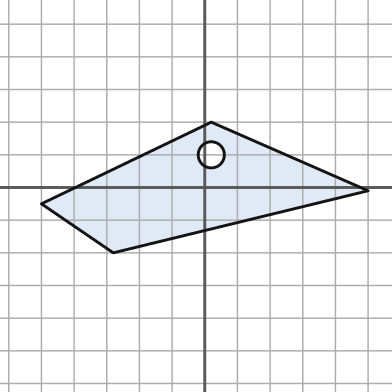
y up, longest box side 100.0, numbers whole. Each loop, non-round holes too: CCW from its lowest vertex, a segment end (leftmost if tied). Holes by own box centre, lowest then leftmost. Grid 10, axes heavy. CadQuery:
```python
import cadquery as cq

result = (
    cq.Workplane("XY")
    .moveTo(-28.0, -20.0)
    .lineTo(50.0, -1.0)
    .lineTo(2.0, 20.0)
    .lineTo(-50.0, -5.0)
    .close()
    .moveTo(2.0, 10.0)
    .circle(4.0)
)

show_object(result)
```